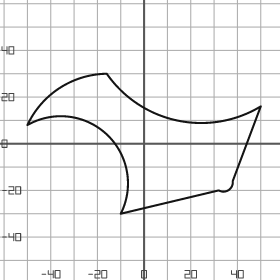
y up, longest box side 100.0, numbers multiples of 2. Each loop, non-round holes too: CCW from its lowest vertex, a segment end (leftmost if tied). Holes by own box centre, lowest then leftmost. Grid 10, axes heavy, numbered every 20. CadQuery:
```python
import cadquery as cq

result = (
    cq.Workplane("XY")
    .moveTo(-10.0, -30.0)
    .lineTo(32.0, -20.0)
    .threePointArc((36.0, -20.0), (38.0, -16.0))
    .lineTo(50.0, 16.0)
    .threePointArc((14.0, 10.0), (-16.0, 30.0))
    .threePointArc((-36.0, 24.0), (-50.0, 8.0))
    .threePointArc((-16.0, 4.0), (-10.0, -30.0))
    .close()
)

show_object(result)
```